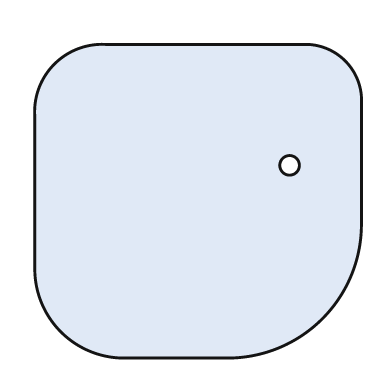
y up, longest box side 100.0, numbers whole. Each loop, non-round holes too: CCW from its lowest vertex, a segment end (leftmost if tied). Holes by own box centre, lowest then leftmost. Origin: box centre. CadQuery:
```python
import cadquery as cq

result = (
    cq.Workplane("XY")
    .moveTo(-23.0, -48.0)
    .lineTo(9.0, -48.0)
    .threePointArc((38.0, -36.0), (50.0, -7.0))
    .lineTo(50.0, 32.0)
    .threePointArc((45.0, 43.0), (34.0, 48.0))
    .lineTo(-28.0, 48.0)
    .threePointArc((-44.0, 42.0), (-50.0, 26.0))
    .lineTo(-50.0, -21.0)
    .threePointArc((-42.0, -40.0), (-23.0, -48.0))
    .close()
    .moveTo(28.0, 11.0)
    .circle(3.0)
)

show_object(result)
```